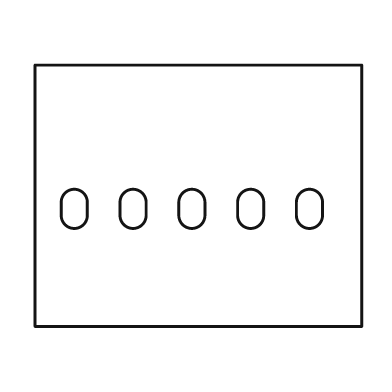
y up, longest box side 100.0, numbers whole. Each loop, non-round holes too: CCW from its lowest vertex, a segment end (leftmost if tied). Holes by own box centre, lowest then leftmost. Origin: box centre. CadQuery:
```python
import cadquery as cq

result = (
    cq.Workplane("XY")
    .moveTo(-50.0, -40.0)
    .lineTo(50.0, -40.0)
    .lineTo(50.0, 40.0)
    .lineTo(-50.0, 40.0)
    .close()
    .moveTo(-42.0, -6.0)
    .threePointArc((-38.0, -10.0), (-34.0, -6.0))
    .lineTo(-34.0, -2.0)
    .threePointArc((-38.0, 2.0), (-42.0, -2.0))
    .close()
    .moveTo(-24.0, -6.0)
    .threePointArc((-20.0, -10.0), (-16.0, -6.0))
    .lineTo(-16.0, -2.0)
    .threePointArc((-20.0, 2.0), (-24.0, -2.0))
    .close()
    .moveTo(-6.0, -6.0)
    .threePointArc((-2.0, -10.0), (2.0, -6.0))
    .lineTo(2.0, -2.0)
    .threePointArc((-2.0, 2.0), (-6.0, -2.0))
    .close()
    .moveTo(12.0, -6.0)
    .threePointArc((16.0, -10.0), (20.0, -6.0))
    .lineTo(20.0, -2.0)
    .threePointArc((16.0, 2.0), (12.0, -2.0))
    .close()
    .moveTo(30.0, -6.0)
    .threePointArc((34.0, -10.0), (38.0, -6.0))
    .lineTo(38.0, -2.0)
    .threePointArc((34.0, 2.0), (30.0, -2.0))
    .close()
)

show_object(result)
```